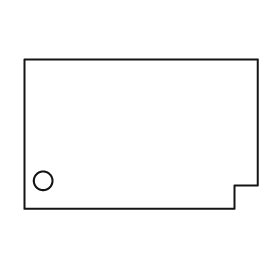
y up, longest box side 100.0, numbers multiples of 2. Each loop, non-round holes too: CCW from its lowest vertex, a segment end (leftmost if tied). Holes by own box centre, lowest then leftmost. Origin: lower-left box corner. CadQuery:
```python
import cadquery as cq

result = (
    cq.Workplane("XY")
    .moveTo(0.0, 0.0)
    .lineTo(90.0, 0.0)
    .lineTo(90.0, 10.0)
    .lineTo(100.0, 10.0)
    .lineTo(100.0, 64.0)
    .lineTo(0.0, 64.0)
    .close()
    .moveTo(8.0, 12.0)
    .circle(4.0)
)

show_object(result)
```